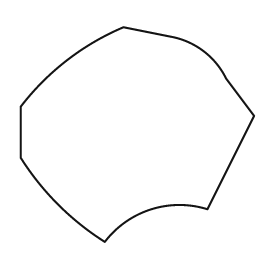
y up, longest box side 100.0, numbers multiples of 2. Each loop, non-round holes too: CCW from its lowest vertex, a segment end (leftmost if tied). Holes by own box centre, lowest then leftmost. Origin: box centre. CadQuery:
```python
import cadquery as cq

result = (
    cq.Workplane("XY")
    .moveTo(-14.0, -46.0)
    .threePointArc((6.0, -32.0), (30.0, -32.0))
    .lineTo(50.0, 8.0)
    .lineTo(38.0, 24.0)
    .threePointArc((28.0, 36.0), (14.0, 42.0))
    .lineTo(-6.0, 46.0)
    .threePointArc((-30.0, 32.0), (-50.0, 12.0))
    .lineTo(-50.0, -10.0)
    .threePointArc((-34.0, -30.0), (-14.0, -46.0))
    .close()
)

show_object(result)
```